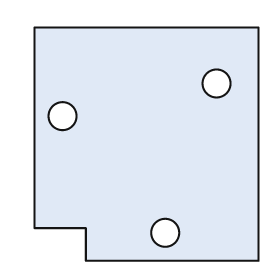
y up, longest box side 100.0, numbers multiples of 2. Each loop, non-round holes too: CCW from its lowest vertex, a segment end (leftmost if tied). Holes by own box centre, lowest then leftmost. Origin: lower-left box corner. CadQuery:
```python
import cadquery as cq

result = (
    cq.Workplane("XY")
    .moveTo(22.0, 0.0)
    .lineTo(96.0, 0.0)
    .lineTo(96.0, 100.0)
    .lineTo(0.0, 100.0)
    .lineTo(0.0, 14.0)
    .lineTo(22.0, 14.0)
    .close()
    .moveTo(56.0, 12.0)
    .circle(6.0)
    .moveTo(12.0, 62.0)
    .circle(6.0)
    .moveTo(78.0, 76.0)
    .circle(6.0)
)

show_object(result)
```